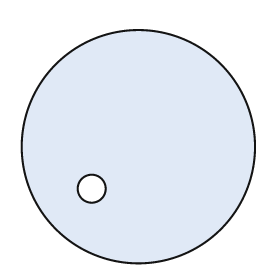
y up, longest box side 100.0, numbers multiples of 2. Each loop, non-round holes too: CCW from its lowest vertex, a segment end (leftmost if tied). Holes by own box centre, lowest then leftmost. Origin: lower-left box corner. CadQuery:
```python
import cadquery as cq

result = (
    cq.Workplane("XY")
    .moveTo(50.0, 50.0)
    .circle(50.0)
    .moveTo(30.0, 32.0)
    .circle(6.0)
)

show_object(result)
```